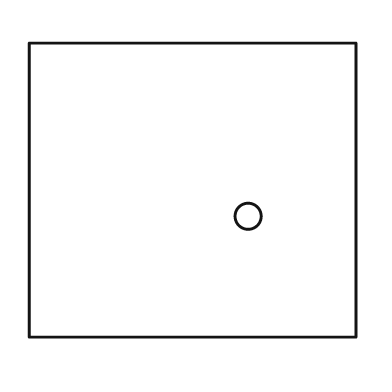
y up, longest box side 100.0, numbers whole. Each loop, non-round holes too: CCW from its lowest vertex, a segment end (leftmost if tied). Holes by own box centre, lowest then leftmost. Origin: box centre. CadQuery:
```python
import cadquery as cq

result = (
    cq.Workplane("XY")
    .moveTo(-50.0, -45.0)
    .lineTo(50.0, -45.0)
    .lineTo(50.0, 45.0)
    .lineTo(-50.0, 45.0)
    .close()
    .moveTo(17.0, -8.0)
    .circle(4.0)
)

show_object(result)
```